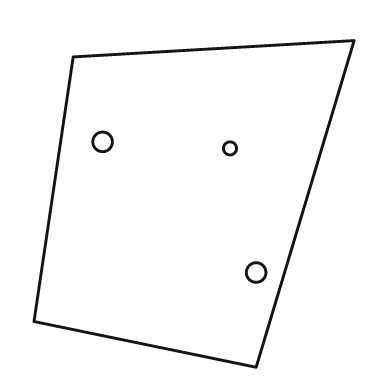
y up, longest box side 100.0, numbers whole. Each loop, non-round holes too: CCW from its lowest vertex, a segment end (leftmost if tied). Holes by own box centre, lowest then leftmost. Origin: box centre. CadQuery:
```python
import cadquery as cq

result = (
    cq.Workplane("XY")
    .moveTo(19.0, -50.0)
    .lineTo(49.0, 50.0)
    .lineTo(-37.0, 45.0)
    .lineTo(-49.0, -36.0)
    .close()
    .moveTo(19.0, -21.0)
    .circle(3.0)
    .moveTo(11.0, 17.0)
    .circle(2.0)
    .moveTo(-28.0, 19.0)
    .circle(3.0)
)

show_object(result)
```